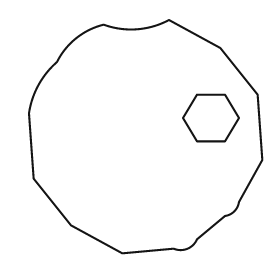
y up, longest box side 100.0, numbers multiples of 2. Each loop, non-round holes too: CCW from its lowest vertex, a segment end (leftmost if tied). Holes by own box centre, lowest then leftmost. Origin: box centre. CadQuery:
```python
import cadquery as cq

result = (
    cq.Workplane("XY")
    .moveTo(-10.0, -50.0)
    .lineTo(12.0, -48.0)
    .threePointArc((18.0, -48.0), (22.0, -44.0))
    .lineTo(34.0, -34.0)
    .threePointArc((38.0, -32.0), (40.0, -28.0))
    .lineTo(50.0, -10.0)
    .lineTo(48.0, 18.0)
    .lineTo(32.0, 38.0)
    .lineTo(10.0, 50.0)
    .threePointArc((-4.0, 46.0), (-18.0, 48.0))
    .threePointArc((-30.0, 42.0), (-38.0, 32.0))
    .threePointArc((-46.0, 22.0), (-50.0, 10.0))
    .lineTo(-48.0, -18.0)
    .lineTo(-32.0, -38.0)
    .close()
    .moveTo(22.0, -2.0)
    .lineTo(34.0, -2.0)
    .lineTo(40.0, 8.0)
    .lineTo(34.0, 18.0)
    .lineTo(22.0, 18.0)
    .lineTo(16.0, 8.0)
    .close()
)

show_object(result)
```